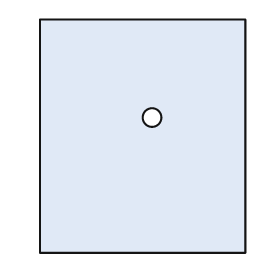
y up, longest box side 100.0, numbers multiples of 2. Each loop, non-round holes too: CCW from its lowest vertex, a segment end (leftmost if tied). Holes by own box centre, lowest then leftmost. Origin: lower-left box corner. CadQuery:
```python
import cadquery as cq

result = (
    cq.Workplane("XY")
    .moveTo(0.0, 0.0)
    .lineTo(88.0, 0.0)
    .lineTo(88.0, 100.0)
    .lineTo(0.0, 100.0)
    .close()
    .moveTo(48.0, 58.0)
    .circle(4.0)
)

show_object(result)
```